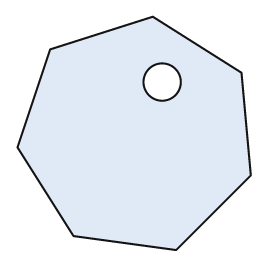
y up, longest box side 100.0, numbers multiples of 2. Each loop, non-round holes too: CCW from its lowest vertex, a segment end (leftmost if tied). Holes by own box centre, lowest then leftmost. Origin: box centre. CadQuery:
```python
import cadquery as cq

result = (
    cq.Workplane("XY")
    .moveTo(18.0, -50.0)
    .lineTo(50.0, -18.0)
    .lineTo(46.0, 26.0)
    .lineTo(8.0, 50.0)
    .lineTo(-36.0, 36.0)
    .lineTo(-50.0, -6.0)
    .lineTo(-26.0, -44.0)
    .close()
    .moveTo(12.0, 22.0)
    .circle(8.0)
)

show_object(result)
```